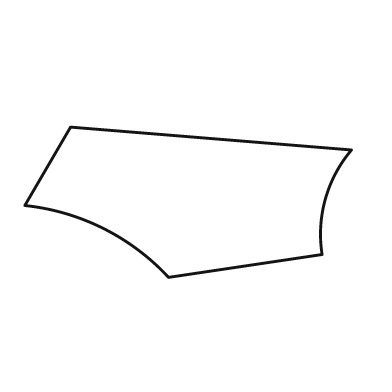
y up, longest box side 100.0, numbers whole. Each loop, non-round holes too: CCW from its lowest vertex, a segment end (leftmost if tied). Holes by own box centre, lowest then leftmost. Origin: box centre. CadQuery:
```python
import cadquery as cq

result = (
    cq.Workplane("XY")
    .moveTo(-6.0, -23.0)
    .lineTo(41.0, -16.0)
    .threePointArc((42.0, 1.0), (50.0, 16.0))
    .lineTo(-36.0, 23.0)
    .lineTo(-50.0, -1.0)
    .threePointArc((-26.0, -8.0), (-6.0, -23.0))
    .close()
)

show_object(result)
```